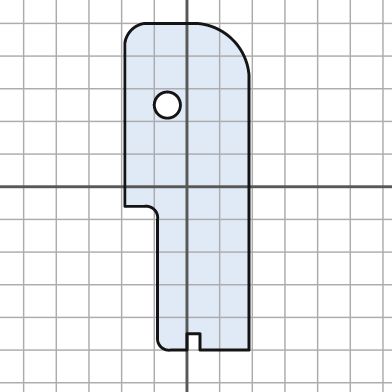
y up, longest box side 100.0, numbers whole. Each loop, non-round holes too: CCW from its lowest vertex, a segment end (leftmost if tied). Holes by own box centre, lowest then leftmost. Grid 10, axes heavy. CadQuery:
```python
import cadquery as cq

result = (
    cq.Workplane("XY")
    .moveTo(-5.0, -50.0)
    .lineTo(0.0, -50.0)
    .lineTo(0.0, -45.0)
    .lineTo(4.0, -45.0)
    .lineTo(4.0, -50.0)
    .lineTo(19.0, -50.0)
    .lineTo(19.0, 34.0)
    .threePointArc((14.0, 45.0), (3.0, 50.0))
    .lineTo(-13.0, 50.0)
    .threePointArc((-17.0, 48.0), (-19.0, 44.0))
    .lineTo(-19.0, -6.0)
    .lineTo(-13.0, -6.0)
    .threePointArc((-10.0, -7.0), (-9.0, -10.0))
    .lineTo(-9.0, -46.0)
    .threePointArc((-8.0, -49.0), (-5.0, -50.0))
    .close()
    .moveTo(-6.0, 25.0)
    .circle(4.0)
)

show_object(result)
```